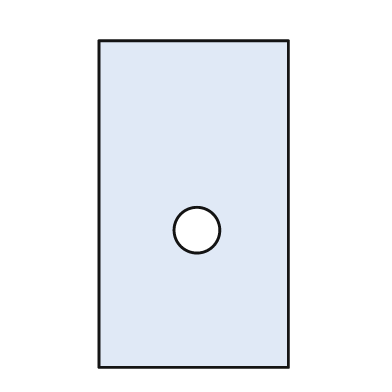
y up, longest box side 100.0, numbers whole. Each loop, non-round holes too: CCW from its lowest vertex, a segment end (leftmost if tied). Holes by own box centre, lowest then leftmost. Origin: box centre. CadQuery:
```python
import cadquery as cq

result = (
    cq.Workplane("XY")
    .moveTo(-29.0, -50.0)
    .lineTo(29.0, -50.0)
    .lineTo(29.0, 50.0)
    .lineTo(-29.0, 50.0)
    .close()
    .moveTo(1.0, -8.0)
    .circle(7.0)
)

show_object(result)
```